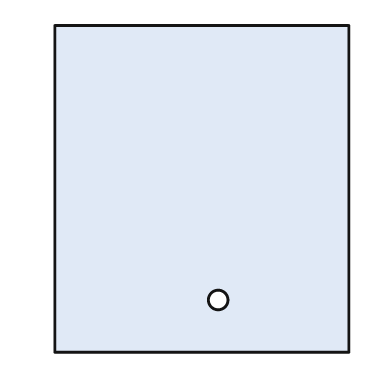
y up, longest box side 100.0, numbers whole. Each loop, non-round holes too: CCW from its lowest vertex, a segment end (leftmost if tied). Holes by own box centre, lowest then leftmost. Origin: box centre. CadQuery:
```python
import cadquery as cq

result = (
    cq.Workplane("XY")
    .moveTo(-45.0, -50.0)
    .lineTo(45.0, -50.0)
    .lineTo(45.0, 50.0)
    .lineTo(-45.0, 50.0)
    .close()
    .moveTo(5.0, -34.0)
    .circle(3.0)
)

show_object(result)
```